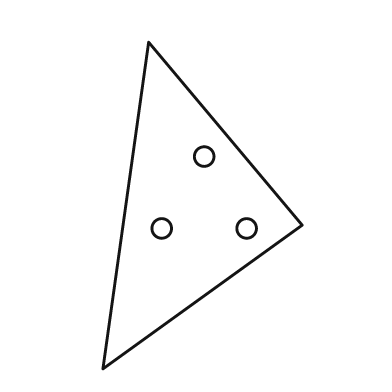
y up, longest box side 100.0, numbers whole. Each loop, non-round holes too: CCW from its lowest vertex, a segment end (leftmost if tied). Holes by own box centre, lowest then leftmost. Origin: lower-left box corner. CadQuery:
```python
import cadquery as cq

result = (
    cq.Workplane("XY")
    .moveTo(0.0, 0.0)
    .lineTo(61.0, 44.0)
    .lineTo(14.0, 100.0)
    .close()
    .moveTo(18.0, 43.0)
    .circle(3.0)
    .moveTo(44.0, 43.0)
    .circle(3.0)
    .moveTo(31.0, 65.0)
    .circle(3.0)
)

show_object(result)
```